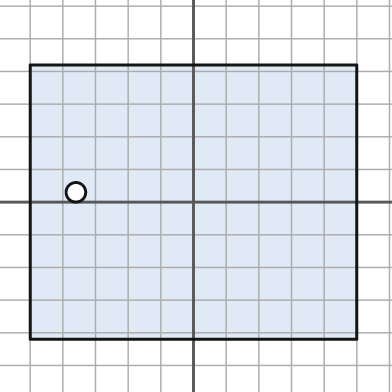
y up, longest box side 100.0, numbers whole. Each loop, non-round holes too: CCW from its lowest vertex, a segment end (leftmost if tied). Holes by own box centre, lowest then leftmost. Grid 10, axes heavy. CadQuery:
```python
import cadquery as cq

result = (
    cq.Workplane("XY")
    .moveTo(-50.0, -42.0)
    .lineTo(50.0, -42.0)
    .lineTo(50.0, 42.0)
    .lineTo(-50.0, 42.0)
    .close()
    .moveTo(-36.0, 3.0)
    .circle(3.0)
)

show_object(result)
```